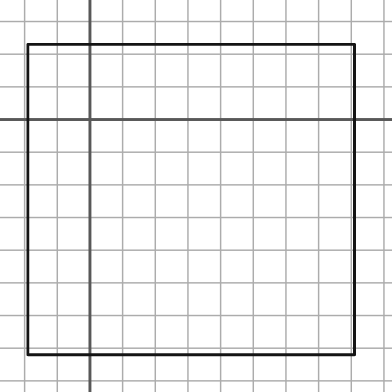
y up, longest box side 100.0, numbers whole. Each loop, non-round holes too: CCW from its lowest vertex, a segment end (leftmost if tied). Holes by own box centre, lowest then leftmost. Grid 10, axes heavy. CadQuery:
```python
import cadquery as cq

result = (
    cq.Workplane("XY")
    .moveTo(-19.0, -72.0)
    .lineTo(81.0, -72.0)
    .lineTo(81.0, 23.0)
    .lineTo(-19.0, 23.0)
    .close()
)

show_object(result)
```